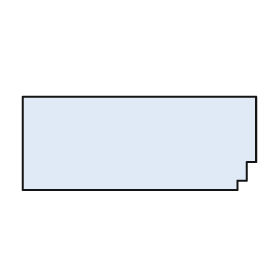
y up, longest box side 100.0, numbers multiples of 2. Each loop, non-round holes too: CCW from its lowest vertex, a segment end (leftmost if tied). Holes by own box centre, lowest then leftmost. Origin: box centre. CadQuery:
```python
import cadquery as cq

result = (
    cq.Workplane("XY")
    .moveTo(-50.0, -20.0)
    .lineTo(42.0, -20.0)
    .lineTo(42.0, -16.0)
    .lineTo(46.0, -16.0)
    .lineTo(46.0, -8.0)
    .lineTo(50.0, -8.0)
    .lineTo(50.0, 20.0)
    .lineTo(-50.0, 20.0)
    .close()
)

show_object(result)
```